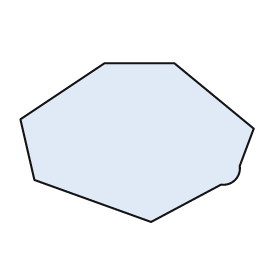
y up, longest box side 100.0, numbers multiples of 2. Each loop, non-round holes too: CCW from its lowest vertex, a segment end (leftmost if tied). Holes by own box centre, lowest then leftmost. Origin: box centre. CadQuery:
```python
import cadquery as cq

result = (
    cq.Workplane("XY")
    .moveTo(6.0, -34.0)
    .lineTo(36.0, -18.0)
    .threePointArc((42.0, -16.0), (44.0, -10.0))
    .lineTo(50.0, 6.0)
    .lineTo(16.0, 34.0)
    .lineTo(-14.0, 34.0)
    .lineTo(-50.0, 10.0)
    .lineTo(-44.0, -16.0)
    .close()
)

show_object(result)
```